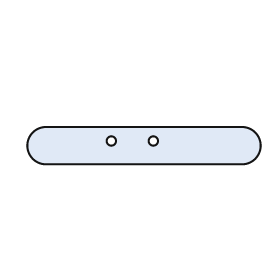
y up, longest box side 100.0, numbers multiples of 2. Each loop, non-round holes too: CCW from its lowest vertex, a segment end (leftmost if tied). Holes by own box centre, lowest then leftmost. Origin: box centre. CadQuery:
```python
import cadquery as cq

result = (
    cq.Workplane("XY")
    .moveTo(-42.0, -8.0)
    .lineTo(42.0, -8.0)
    .threePointArc((50.0, 0.0), (42.0, 8.0))
    .lineTo(-42.0, 8.0)
    .threePointArc((-50.0, 0.0), (-42.0, -8.0))
    .close()
    .moveTo(-14.0, 2.0)
    .circle(2.0)
    .moveTo(4.0, 2.0)
    .circle(2.0)
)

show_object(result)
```